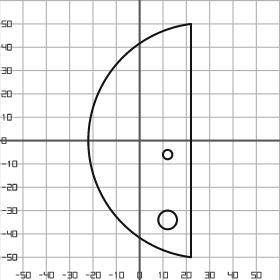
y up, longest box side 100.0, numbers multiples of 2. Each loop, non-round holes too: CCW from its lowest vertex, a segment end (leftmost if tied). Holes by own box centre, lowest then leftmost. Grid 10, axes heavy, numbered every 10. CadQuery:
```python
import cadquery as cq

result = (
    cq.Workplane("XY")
    .moveTo(22.0, -50.0)
    .lineTo(22.0, 50.0)
    .threePointArc((-22.0, 0.0), (22.0, -50.0))
    .close()
    .moveTo(12.0, -34.0)
    .circle(4.0)
    .moveTo(12.0, -6.0)
    .circle(2.0)
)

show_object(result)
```